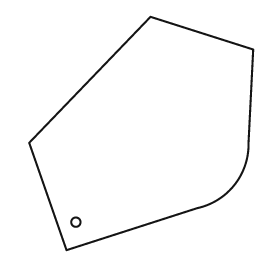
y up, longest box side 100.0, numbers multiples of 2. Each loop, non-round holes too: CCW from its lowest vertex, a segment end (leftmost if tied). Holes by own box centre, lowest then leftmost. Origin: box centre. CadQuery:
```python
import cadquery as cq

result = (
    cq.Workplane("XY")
    .moveTo(-32.0, -50.0)
    .lineTo(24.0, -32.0)
    .threePointArc((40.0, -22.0), (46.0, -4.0))
    .lineTo(48.0, 36.0)
    .lineTo(4.0, 50.0)
    .lineTo(-48.0, -4.0)
    .close()
    .moveTo(-28.0, -38.0)
    .circle(2.0)
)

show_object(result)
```